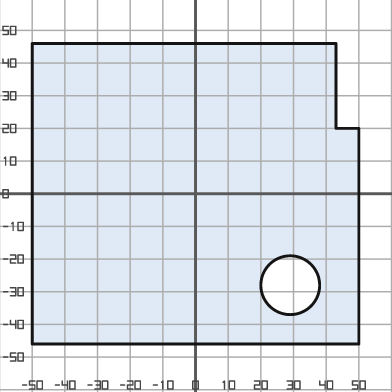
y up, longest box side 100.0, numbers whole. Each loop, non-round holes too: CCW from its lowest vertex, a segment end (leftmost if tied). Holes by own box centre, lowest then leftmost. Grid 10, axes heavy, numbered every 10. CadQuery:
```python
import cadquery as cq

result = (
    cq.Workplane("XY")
    .moveTo(-50.0, -46.0)
    .lineTo(50.0, -46.0)
    .lineTo(50.0, 20.0)
    .lineTo(43.0, 20.0)
    .lineTo(43.0, 46.0)
    .lineTo(-50.0, 46.0)
    .close()
    .moveTo(29.0, -28.0)
    .circle(9.0)
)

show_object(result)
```